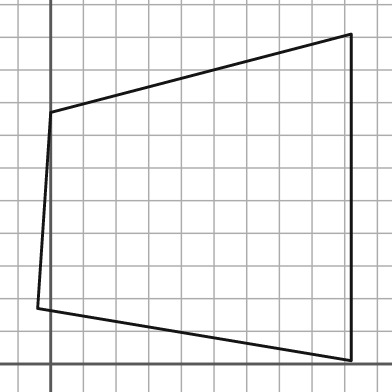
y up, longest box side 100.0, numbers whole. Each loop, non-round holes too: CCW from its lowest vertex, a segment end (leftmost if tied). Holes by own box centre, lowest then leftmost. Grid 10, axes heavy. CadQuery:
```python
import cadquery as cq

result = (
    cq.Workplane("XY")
    .moveTo(92.0, 1.0)
    .lineTo(92.0, 101.0)
    .lineTo(0.0, 77.0)
    .lineTo(-4.0, 17.0)
    .close()
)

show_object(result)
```